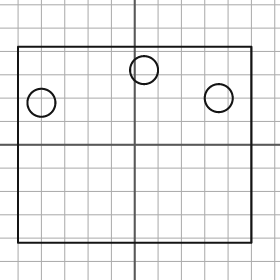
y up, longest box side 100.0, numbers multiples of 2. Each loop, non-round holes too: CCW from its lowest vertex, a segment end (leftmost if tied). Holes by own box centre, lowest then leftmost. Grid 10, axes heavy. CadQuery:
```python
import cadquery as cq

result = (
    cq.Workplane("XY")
    .moveTo(-50.0, -42.0)
    .lineTo(50.0, -42.0)
    .lineTo(50.0, 42.0)
    .lineTo(-50.0, 42.0)
    .close()
    .moveTo(-40.0, 18.0)
    .circle(6.0)
    .moveTo(36.0, 20.0)
    .circle(6.0)
    .moveTo(4.0, 32.0)
    .circle(6.0)
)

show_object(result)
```